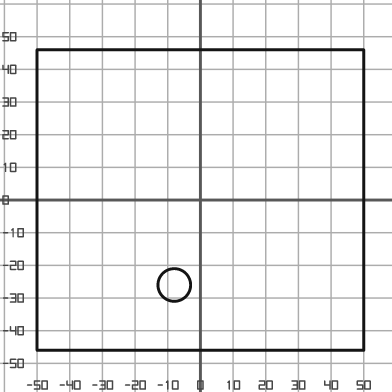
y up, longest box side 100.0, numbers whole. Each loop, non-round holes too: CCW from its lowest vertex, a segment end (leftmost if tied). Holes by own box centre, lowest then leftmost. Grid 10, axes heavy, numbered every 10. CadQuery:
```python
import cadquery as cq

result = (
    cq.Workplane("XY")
    .moveTo(-50.0, -46.0)
    .lineTo(50.0, -46.0)
    .lineTo(50.0, 46.0)
    .lineTo(-50.0, 46.0)
    .close()
    .moveTo(-8.0, -26.0)
    .circle(5.0)
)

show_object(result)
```